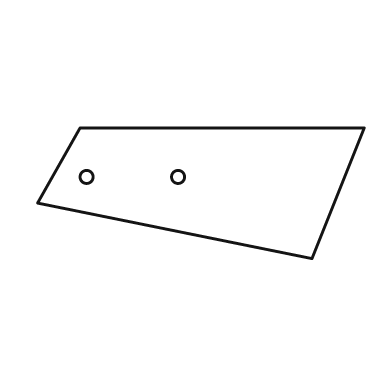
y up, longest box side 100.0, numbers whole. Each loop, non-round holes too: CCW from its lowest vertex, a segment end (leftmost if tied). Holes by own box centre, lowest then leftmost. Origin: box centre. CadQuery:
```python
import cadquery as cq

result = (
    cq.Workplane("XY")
    .moveTo(34.0, -20.0)
    .lineTo(50.0, 20.0)
    .lineTo(-37.0, 20.0)
    .lineTo(-50.0, -3.0)
    .close()
    .moveTo(-35.0, 5.0)
    .circle(2.0)
    .moveTo(-7.0, 5.0)
    .circle(2.0)
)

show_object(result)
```